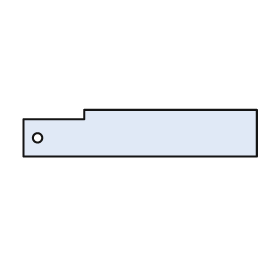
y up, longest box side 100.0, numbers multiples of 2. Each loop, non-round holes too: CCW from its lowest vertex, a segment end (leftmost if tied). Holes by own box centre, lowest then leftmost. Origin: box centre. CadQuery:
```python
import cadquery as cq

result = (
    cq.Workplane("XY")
    .moveTo(-50.0, -10.0)
    .lineTo(50.0, -10.0)
    .lineTo(50.0, 10.0)
    .lineTo(-24.0, 10.0)
    .lineTo(-24.0, 6.0)
    .lineTo(-50.0, 6.0)
    .close()
    .moveTo(-44.0, -2.0)
    .circle(2.0)
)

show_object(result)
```